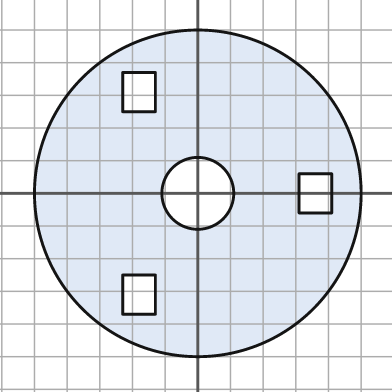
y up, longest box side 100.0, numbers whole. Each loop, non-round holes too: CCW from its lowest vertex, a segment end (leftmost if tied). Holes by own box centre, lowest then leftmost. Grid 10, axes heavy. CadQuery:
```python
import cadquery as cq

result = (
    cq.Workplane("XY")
    .moveTo(0.0, 0.0)
    .circle(50.0)
    .moveTo(-23.0, -37.0)
    .lineTo(-13.0, -37.0)
    .lineTo(-13.0, -25.0)
    .lineTo(-23.0, -25.0)
    .close()
    .moveTo(0.0, 0.0)
    .circle(11.0)
    .moveTo(31.0, -6.0)
    .lineTo(41.0, -6.0)
    .lineTo(41.0, 6.0)
    .lineTo(31.0, 6.0)
    .close()
    .moveTo(-23.0, 25.0)
    .lineTo(-13.0, 25.0)
    .lineTo(-13.0, 37.0)
    .lineTo(-23.0, 37.0)
    .close()
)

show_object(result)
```